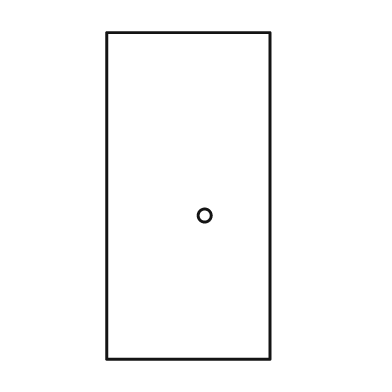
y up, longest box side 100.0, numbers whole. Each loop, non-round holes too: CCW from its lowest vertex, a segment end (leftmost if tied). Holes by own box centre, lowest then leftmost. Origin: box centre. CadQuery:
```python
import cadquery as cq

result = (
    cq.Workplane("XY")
    .moveTo(-25.0, -50.0)
    .lineTo(25.0, -50.0)
    .lineTo(25.0, 50.0)
    .lineTo(-25.0, 50.0)
    .close()
    .moveTo(5.0, -6.0)
    .circle(2.0)
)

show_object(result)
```